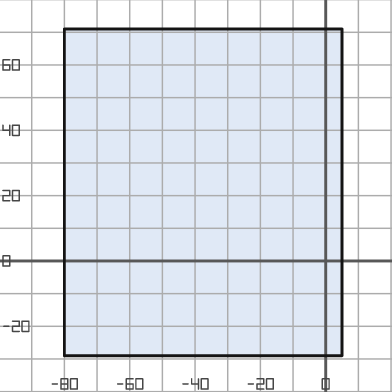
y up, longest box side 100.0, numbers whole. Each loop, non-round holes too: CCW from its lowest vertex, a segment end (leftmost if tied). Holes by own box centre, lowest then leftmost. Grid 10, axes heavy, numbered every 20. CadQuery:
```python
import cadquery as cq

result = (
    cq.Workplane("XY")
    .moveTo(-80.0, -29.0)
    .lineTo(5.0, -29.0)
    .lineTo(5.0, 71.0)
    .lineTo(-80.0, 71.0)
    .close()
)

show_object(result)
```